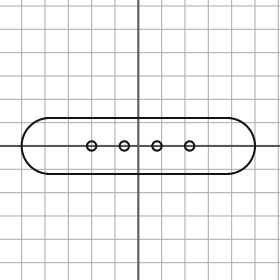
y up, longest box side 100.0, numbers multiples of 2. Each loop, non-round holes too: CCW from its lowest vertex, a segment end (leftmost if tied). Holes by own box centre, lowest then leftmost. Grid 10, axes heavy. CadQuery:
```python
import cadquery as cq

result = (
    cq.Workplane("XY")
    .moveTo(-38.0, -12.0)
    .lineTo(38.0, -12.0)
    .threePointArc((50.0, 0.0), (38.0, 12.0))
    .lineTo(-38.0, 12.0)
    .threePointArc((-50.0, 0.0), (-38.0, -12.0))
    .close()
    .moveTo(-20.0, 0.0)
    .circle(2.0)
    .moveTo(-6.0, 0.0)
    .circle(2.0)
    .moveTo(8.0, 0.0)
    .circle(2.0)
    .moveTo(22.0, 0.0)
    .circle(2.0)
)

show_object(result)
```